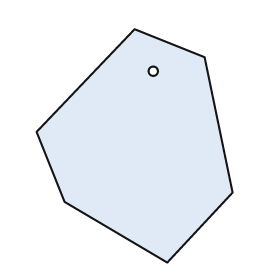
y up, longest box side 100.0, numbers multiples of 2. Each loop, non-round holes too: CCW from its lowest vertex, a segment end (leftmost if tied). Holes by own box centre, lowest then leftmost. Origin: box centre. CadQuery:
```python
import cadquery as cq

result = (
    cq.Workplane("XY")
    .moveTo(14.0, -50.0)
    .lineTo(42.0, -20.0)
    .lineTo(30.0, 38.0)
    .lineTo(0.0, 50.0)
    .lineTo(-42.0, 6.0)
    .lineTo(-30.0, -24.0)
    .close()
    .moveTo(8.0, 32.0)
    .circle(2.0)
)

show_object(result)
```